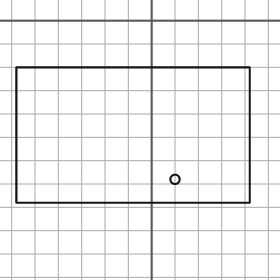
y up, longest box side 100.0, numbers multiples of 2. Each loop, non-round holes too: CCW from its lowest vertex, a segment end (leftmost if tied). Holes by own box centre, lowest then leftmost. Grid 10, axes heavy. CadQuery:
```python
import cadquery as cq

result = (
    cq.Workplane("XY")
    .moveTo(-58.0, -78.0)
    .lineTo(42.0, -78.0)
    .lineTo(42.0, -20.0)
    .lineTo(-58.0, -20.0)
    .close()
    .moveTo(10.0, -68.0)
    .circle(2.0)
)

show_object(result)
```